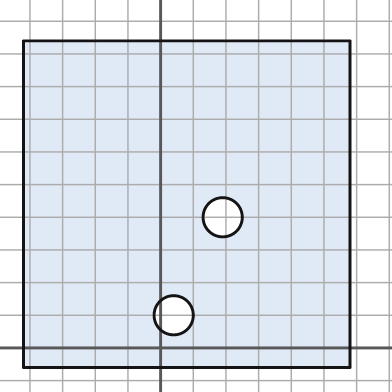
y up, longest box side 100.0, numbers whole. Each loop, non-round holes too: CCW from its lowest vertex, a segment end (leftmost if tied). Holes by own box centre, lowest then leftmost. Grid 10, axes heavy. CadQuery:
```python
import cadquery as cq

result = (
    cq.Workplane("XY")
    .moveTo(-42.0, -6.0)
    .lineTo(58.0, -6.0)
    .lineTo(58.0, 94.0)
    .lineTo(-42.0, 94.0)
    .close()
    .moveTo(4.0, 10.0)
    .circle(6.0)
    .moveTo(19.0, 40.0)
    .circle(6.0)
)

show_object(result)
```